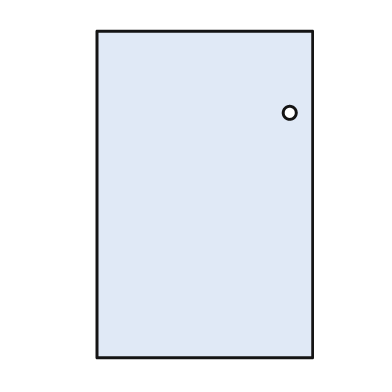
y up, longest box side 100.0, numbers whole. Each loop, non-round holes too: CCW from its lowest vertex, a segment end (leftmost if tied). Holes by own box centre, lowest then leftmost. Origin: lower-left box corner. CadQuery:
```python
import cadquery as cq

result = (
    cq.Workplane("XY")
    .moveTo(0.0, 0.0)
    .lineTo(66.0, 0.0)
    .lineTo(66.0, 100.0)
    .lineTo(0.0, 100.0)
    .close()
    .moveTo(59.0, 75.0)
    .circle(2.0)
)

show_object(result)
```